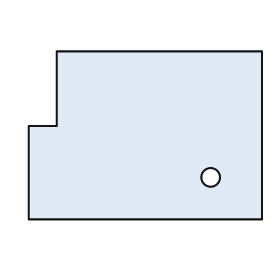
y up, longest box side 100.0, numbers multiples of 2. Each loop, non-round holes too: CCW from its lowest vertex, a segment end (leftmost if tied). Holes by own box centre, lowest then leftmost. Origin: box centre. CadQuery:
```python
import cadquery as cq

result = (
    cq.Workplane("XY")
    .moveTo(-50.0, -36.0)
    .lineTo(50.0, -36.0)
    .lineTo(50.0, 36.0)
    .lineTo(-38.0, 36.0)
    .lineTo(-38.0, 4.0)
    .lineTo(-50.0, 4.0)
    .close()
    .moveTo(28.0, -18.0)
    .circle(4.0)
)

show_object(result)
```